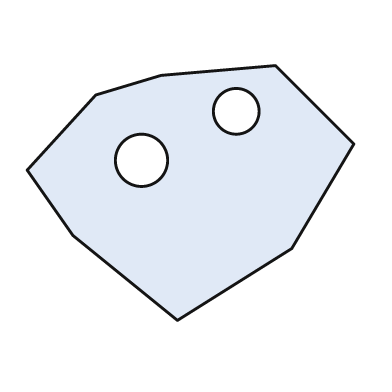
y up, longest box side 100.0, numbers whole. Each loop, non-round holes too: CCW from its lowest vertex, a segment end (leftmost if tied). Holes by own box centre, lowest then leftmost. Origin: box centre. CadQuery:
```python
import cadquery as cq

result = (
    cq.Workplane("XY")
    .moveTo(-4.0, -39.0)
    .lineTo(31.0, -17.0)
    .lineTo(50.0, 15.0)
    .lineTo(26.0, 39.0)
    .lineTo(-9.0, 36.0)
    .lineTo(-29.0, 30.0)
    .lineTo(-50.0, 7.0)
    .lineTo(-36.0, -13.0)
    .close()
    .moveTo(-15.0, 10.0)
    .circle(8.0)
    .moveTo(14.0, 25.0)
    .circle(7.0)
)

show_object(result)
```